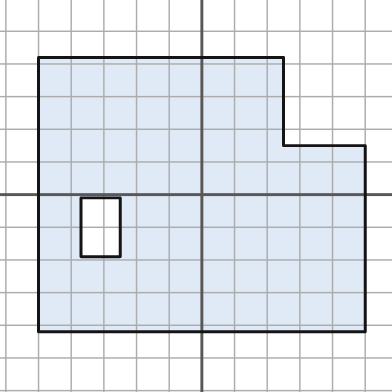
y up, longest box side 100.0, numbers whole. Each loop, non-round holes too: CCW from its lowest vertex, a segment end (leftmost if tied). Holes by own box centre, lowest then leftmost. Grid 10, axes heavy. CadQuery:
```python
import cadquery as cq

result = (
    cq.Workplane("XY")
    .moveTo(-50.0, -42.0)
    .lineTo(50.0, -42.0)
    .lineTo(50.0, 15.0)
    .lineTo(25.0, 15.0)
    .lineTo(25.0, 42.0)
    .lineTo(-50.0, 42.0)
    .close()
    .moveTo(-37.0, -19.0)
    .lineTo(-25.0, -19.0)
    .lineTo(-25.0, -1.0)
    .lineTo(-37.0, -1.0)
    .close()
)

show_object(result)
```